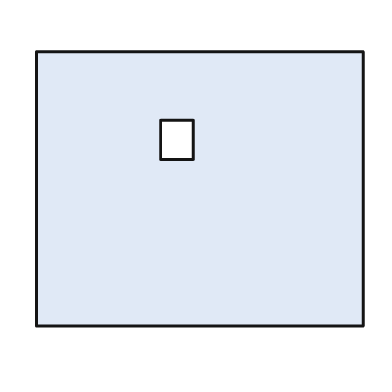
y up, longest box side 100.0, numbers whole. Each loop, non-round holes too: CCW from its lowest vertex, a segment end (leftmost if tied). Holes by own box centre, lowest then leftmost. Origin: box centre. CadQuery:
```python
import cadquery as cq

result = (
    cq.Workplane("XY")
    .moveTo(-50.0, -42.0)
    .lineTo(50.0, -42.0)
    .lineTo(50.0, 42.0)
    .lineTo(-50.0, 42.0)
    .close()
    .moveTo(-12.0, 9.0)
    .lineTo(-2.0, 9.0)
    .lineTo(-2.0, 21.0)
    .lineTo(-12.0, 21.0)
    .close()
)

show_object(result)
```